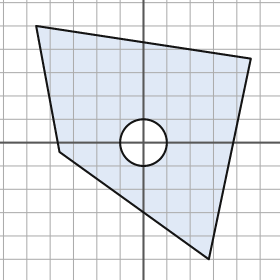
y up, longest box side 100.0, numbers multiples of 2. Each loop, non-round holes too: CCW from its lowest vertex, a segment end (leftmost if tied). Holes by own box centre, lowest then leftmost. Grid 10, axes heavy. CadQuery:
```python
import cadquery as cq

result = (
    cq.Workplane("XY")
    .moveTo(28.0, -50.0)
    .lineTo(46.0, 36.0)
    .lineTo(-46.0, 50.0)
    .lineTo(-36.0, -4.0)
    .close()
    .moveTo(0.0, 0.0)
    .circle(10.0)
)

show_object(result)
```